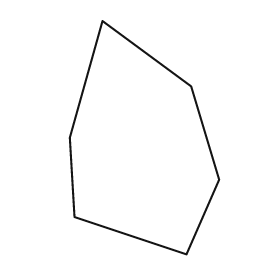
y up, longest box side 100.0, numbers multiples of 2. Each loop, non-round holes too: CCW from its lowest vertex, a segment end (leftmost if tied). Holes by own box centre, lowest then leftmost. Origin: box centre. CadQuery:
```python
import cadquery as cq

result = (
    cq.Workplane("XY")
    .moveTo(18.0, -50.0)
    .lineTo(32.0, -18.0)
    .lineTo(20.0, 22.0)
    .lineTo(-18.0, 50.0)
    .lineTo(-32.0, 0.0)
    .lineTo(-30.0, -34.0)
    .close()
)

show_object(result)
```